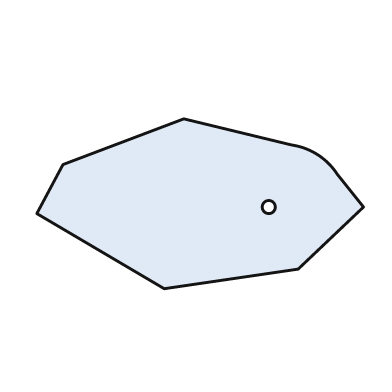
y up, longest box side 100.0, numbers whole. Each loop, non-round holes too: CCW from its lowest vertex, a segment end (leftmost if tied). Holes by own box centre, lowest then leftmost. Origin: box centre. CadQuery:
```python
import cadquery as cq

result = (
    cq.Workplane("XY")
    .moveTo(-11.0, -26.0)
    .lineTo(30.0, -20.0)
    .lineTo(50.0, -1.0)
    .lineTo(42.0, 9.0)
    .threePointArc((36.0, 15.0), (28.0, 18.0))
    .lineTo(-5.0, 26.0)
    .lineTo(-42.0, 12.0)
    .lineTo(-50.0, -3.0)
    .close()
    .moveTo(21.0, -1.0)
    .circle(2.0)
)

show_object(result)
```